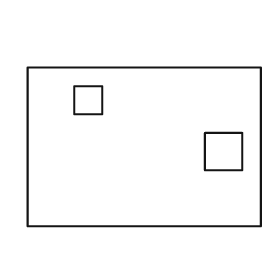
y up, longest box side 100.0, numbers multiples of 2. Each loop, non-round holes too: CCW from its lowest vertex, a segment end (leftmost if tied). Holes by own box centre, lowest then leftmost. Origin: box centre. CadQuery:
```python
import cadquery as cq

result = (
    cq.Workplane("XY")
    .moveTo(-50.0, -34.0)
    .lineTo(50.0, -34.0)
    .lineTo(50.0, 34.0)
    .lineTo(-50.0, 34.0)
    .close()
    .moveTo(26.0, -10.0)
    .lineTo(42.0, -10.0)
    .lineTo(42.0, 6.0)
    .lineTo(26.0, 6.0)
    .close()
    .moveTo(-30.0, 14.0)
    .lineTo(-18.0, 14.0)
    .lineTo(-18.0, 26.0)
    .lineTo(-30.0, 26.0)
    .close()
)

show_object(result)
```